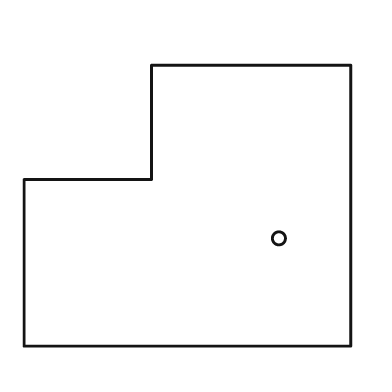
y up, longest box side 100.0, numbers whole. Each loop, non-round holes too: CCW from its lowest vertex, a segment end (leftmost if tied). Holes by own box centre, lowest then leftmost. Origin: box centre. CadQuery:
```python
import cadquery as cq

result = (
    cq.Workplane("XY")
    .moveTo(-50.0, -43.0)
    .lineTo(50.0, -43.0)
    .lineTo(50.0, 43.0)
    .lineTo(-11.0, 43.0)
    .lineTo(-11.0, 8.0)
    .lineTo(-50.0, 8.0)
    .close()
    .moveTo(28.0, -10.0)
    .circle(2.0)
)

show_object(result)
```